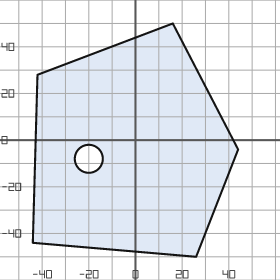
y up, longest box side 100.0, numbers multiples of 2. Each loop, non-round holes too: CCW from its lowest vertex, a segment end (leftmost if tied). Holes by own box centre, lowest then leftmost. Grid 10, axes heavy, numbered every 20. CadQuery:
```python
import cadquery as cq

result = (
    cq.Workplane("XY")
    .moveTo(26.0, -50.0)
    .lineTo(44.0, -4.0)
    .lineTo(16.0, 50.0)
    .lineTo(-42.0, 28.0)
    .lineTo(-44.0, -44.0)
    .close()
    .moveTo(-20.0, -8.0)
    .circle(6.0)
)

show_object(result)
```